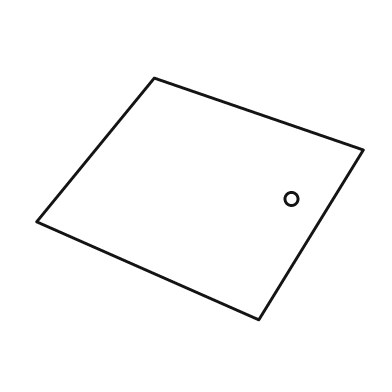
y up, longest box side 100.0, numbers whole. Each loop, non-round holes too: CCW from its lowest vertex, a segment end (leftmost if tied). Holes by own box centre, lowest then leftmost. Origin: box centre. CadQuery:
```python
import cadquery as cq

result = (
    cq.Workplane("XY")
    .moveTo(18.0, -37.0)
    .lineTo(50.0, 15.0)
    .lineTo(-14.0, 37.0)
    .lineTo(-50.0, -7.0)
    .close()
    .moveTo(28.0, 0.0)
    .circle(2.0)
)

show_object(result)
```